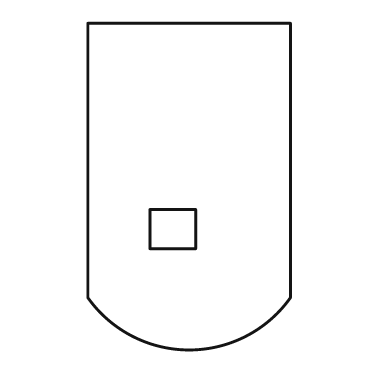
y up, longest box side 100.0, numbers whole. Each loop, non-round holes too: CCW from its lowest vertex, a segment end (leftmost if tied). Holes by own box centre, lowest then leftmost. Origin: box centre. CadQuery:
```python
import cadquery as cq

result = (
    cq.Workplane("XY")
    .moveTo(-31.0, -34.0)
    .threePointArc((0.0, -50.0), (31.0, -34.0))
    .lineTo(31.0, 50.0)
    .lineTo(-31.0, 50.0)
    .close()
    .moveTo(-12.0, -19.0)
    .lineTo(2.0, -19.0)
    .lineTo(2.0, -7.0)
    .lineTo(-12.0, -7.0)
    .close()
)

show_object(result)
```